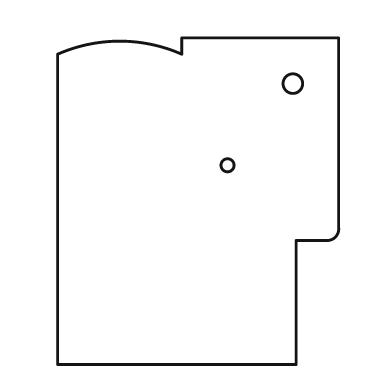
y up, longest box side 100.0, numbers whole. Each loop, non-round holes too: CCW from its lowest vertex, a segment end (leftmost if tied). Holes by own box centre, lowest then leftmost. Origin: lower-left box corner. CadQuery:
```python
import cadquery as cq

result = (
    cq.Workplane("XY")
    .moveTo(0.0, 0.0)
    .lineTo(73.0, 0.0)
    .lineTo(73.0, 38.0)
    .lineTo(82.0, 38.0)
    .threePointArc((85.0, 39.0), (86.0, 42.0))
    .lineTo(86.0, 100.0)
    .lineTo(38.0, 100.0)
    .lineTo(38.0, 95.0)
    .threePointArc((19.0, 99.0), (0.0, 95.0))
    .close()
    .moveTo(52.0, 61.0)
    .circle(2.0)
    .moveTo(72.0, 86.0)
    .circle(3.0)
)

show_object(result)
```